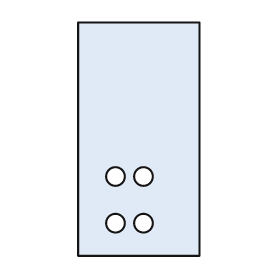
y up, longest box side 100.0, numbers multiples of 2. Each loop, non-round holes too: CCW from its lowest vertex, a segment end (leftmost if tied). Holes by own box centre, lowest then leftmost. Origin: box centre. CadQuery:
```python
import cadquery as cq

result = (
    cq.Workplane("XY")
    .moveTo(-26.0, -50.0)
    .lineTo(26.0, -50.0)
    .lineTo(26.0, 50.0)
    .lineTo(-26.0, 50.0)
    .close()
    .moveTo(-10.0, -36.0)
    .circle(4.0)
    .moveTo(2.0, -36.0)
    .circle(4.0)
    .moveTo(-10.0, -16.0)
    .circle(4.0)
    .moveTo(2.0, -16.0)
    .circle(4.0)
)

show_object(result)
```